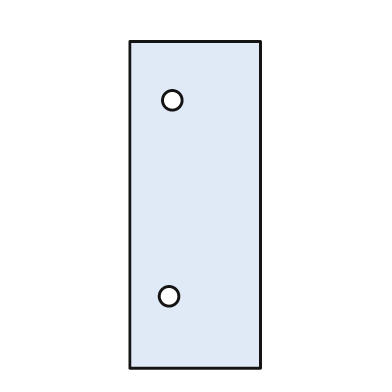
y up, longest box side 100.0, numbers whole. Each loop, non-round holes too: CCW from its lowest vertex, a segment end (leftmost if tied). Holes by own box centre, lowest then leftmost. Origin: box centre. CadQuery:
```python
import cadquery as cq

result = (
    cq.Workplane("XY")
    .moveTo(-20.0, -50.0)
    .lineTo(20.0, -50.0)
    .lineTo(20.0, 50.0)
    .lineTo(-20.0, 50.0)
    .close()
    .moveTo(-8.0, -28.0)
    .circle(3.0)
    .moveTo(-7.0, 32.0)
    .circle(3.0)
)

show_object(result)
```